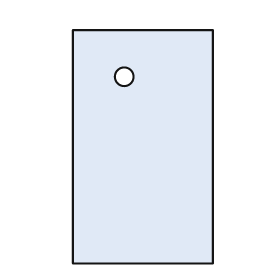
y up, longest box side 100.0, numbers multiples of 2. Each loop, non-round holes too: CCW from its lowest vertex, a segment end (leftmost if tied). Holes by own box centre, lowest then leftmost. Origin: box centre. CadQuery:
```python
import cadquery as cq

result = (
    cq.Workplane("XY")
    .moveTo(-30.0, -50.0)
    .lineTo(30.0, -50.0)
    .lineTo(30.0, 50.0)
    .lineTo(-30.0, 50.0)
    .close()
    .moveTo(-8.0, 30.0)
    .circle(4.0)
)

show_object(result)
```